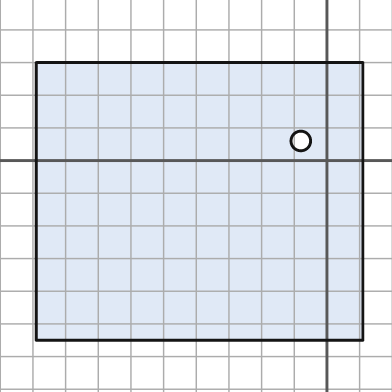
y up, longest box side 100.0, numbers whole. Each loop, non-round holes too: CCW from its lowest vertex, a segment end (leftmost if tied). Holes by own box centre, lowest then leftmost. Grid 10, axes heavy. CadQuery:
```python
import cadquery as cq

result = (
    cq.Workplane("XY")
    .moveTo(-89.0, -55.0)
    .lineTo(11.0, -55.0)
    .lineTo(11.0, 30.0)
    .lineTo(-89.0, 30.0)
    .close()
    .moveTo(-8.0, 6.0)
    .circle(3.0)
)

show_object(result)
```